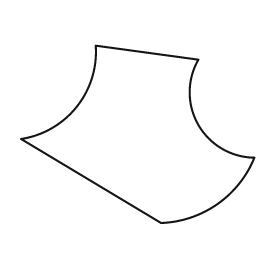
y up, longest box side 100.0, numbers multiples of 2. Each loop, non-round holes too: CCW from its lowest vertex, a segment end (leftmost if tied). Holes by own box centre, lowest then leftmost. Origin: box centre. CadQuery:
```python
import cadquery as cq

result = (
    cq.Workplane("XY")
    .moveTo(10.0, -38.0)
    .threePointArc((34.0, -30.0), (50.0, -10.0))
    .threePointArc((26.0, 4.0), (26.0, 32.0))
    .lineTo(-18.0, 38.0)
    .threePointArc((-26.0, 12.0), (-50.0, -2.0))
    .close()
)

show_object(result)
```